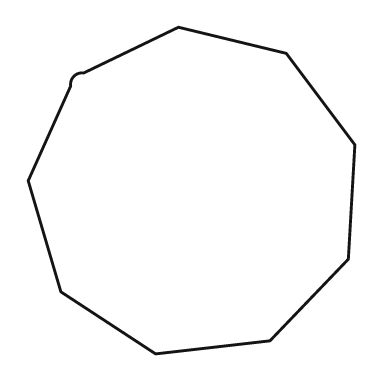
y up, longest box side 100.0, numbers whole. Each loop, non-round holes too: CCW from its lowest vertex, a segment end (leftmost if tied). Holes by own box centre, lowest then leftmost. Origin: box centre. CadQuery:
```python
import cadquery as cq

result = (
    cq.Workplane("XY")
    .moveTo(-11.0, -50.0)
    .lineTo(24.0, -46.0)
    .lineTo(48.0, -21.0)
    .lineTo(50.0, 14.0)
    .lineTo(29.0, 42.0)
    .lineTo(-4.0, 50.0)
    .lineTo(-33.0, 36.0)
    .threePointArc((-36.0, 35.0), (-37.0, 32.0))
    .lineTo(-50.0, 3.0)
    .lineTo(-40.0, -31.0)
    .close()
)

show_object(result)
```